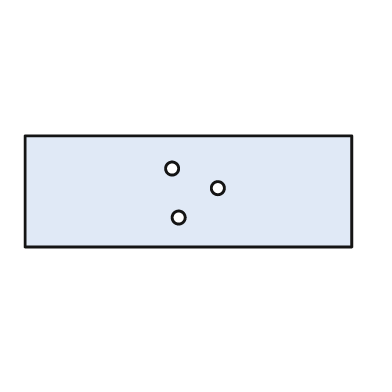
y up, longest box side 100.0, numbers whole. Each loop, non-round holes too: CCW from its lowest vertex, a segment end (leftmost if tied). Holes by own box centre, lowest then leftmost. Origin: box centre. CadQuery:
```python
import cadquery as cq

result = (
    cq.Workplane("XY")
    .moveTo(-50.0, -17.0)
    .lineTo(50.0, -17.0)
    .lineTo(50.0, 17.0)
    .lineTo(-50.0, 17.0)
    .close()
    .moveTo(-3.0, -8.0)
    .circle(2.0)
    .moveTo(9.0, 1.0)
    .circle(2.0)
    .moveTo(-5.0, 7.0)
    .circle(2.0)
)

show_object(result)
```